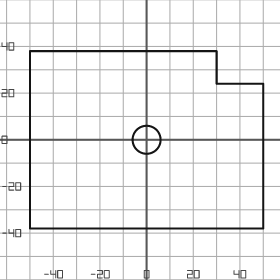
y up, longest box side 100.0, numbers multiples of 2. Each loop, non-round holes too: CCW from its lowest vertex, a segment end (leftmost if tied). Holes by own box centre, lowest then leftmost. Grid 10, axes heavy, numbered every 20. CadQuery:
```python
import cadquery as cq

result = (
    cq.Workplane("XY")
    .moveTo(-50.0, -38.0)
    .lineTo(50.0, -38.0)
    .lineTo(50.0, 24.0)
    .lineTo(30.0, 24.0)
    .lineTo(30.0, 38.0)
    .lineTo(-50.0, 38.0)
    .close()
    .moveTo(0.0, 0.0)
    .circle(6.0)
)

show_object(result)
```